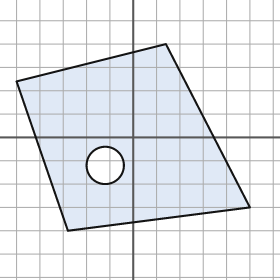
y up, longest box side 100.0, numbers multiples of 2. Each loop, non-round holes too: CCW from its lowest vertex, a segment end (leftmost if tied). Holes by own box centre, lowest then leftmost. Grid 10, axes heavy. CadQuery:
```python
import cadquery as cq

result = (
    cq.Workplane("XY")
    .moveTo(-28.0, -40.0)
    .lineTo(50.0, -30.0)
    .lineTo(14.0, 40.0)
    .lineTo(-50.0, 24.0)
    .close()
    .moveTo(-12.0, -12.0)
    .circle(8.0)
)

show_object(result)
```